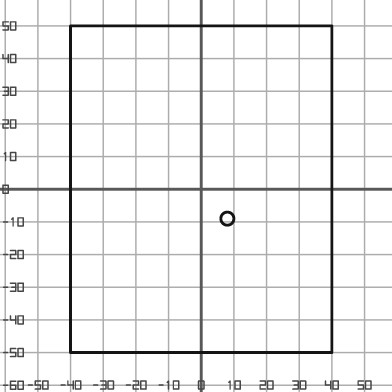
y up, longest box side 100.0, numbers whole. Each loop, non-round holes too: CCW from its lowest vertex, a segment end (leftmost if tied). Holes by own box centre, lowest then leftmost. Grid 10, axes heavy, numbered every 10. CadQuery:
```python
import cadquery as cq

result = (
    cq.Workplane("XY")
    .moveTo(-40.0, -50.0)
    .lineTo(40.0, -50.0)
    .lineTo(40.0, 50.0)
    .lineTo(-40.0, 50.0)
    .close()
    .moveTo(8.0, -9.0)
    .circle(2.0)
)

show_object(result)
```